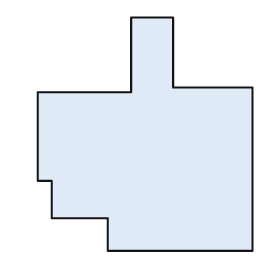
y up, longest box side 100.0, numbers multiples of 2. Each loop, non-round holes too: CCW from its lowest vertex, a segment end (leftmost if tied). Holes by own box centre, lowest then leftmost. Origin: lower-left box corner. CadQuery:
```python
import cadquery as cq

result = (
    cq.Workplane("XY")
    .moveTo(30.0, 0.0)
    .lineTo(92.0, 0.0)
    .lineTo(92.0, 70.0)
    .lineTo(58.0, 70.0)
    .lineTo(58.0, 100.0)
    .lineTo(40.0, 100.0)
    .lineTo(40.0, 68.0)
    .lineTo(0.0, 68.0)
    .lineTo(0.0, 30.0)
    .lineTo(6.0, 30.0)
    .lineTo(6.0, 14.0)
    .lineTo(30.0, 14.0)
    .close()
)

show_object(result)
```